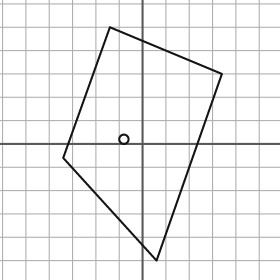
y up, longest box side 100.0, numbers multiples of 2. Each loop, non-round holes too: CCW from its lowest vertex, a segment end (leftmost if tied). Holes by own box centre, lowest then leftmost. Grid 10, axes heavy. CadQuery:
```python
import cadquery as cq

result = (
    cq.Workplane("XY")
    .moveTo(6.0, -50.0)
    .lineTo(34.0, 30.0)
    .lineTo(-14.0, 50.0)
    .lineTo(-34.0, -6.0)
    .close()
    .moveTo(-8.0, 2.0)
    .circle(2.0)
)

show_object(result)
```